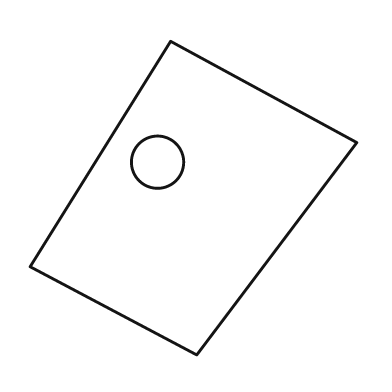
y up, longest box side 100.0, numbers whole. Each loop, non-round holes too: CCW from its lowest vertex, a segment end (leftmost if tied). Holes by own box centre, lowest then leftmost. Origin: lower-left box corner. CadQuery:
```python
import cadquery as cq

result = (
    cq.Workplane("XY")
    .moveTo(51.0, 0.0)
    .lineTo(100.0, 65.0)
    .lineTo(43.0, 96.0)
    .lineTo(0.0, 27.0)
    .close()
    .moveTo(39.0, 59.0)
    .circle(8.0)
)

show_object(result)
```